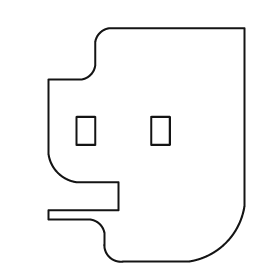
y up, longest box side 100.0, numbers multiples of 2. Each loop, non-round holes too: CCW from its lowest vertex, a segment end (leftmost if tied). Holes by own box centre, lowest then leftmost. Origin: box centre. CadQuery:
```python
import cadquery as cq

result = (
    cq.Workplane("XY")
    .moveTo(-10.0, -50.0)
    .lineTo(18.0, -50.0)
    .threePointArc((34.0, -42.0), (42.0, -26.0))
    .lineTo(42.0, 50.0)
    .lineTo(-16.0, 50.0)
    .threePointArc((-20.0, 48.0), (-22.0, 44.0))
    .lineTo(-22.0, 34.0)
    .threePointArc((-24.0, 30.0), (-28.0, 28.0))
    .lineTo(-42.0, 28.0)
    .lineTo(-42.0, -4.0)
    .threePointArc((-38.0, -12.0), (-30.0, -16.0))
    .lineTo(-12.0, -16.0)
    .lineTo(-12.0, -28.0)
    .lineTo(-42.0, -28.0)
    .lineTo(-42.0, -32.0)
    .lineTo(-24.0, -32.0)
    .threePointArc((-20.0, -34.0), (-18.0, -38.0))
    .lineTo(-18.0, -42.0)
    .threePointArc((-16.0, -48.0), (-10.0, -50.0))
    .close()
    .moveTo(-30.0, 0.0)
    .lineTo(-22.0, 0.0)
    .lineTo(-22.0, 12.0)
    .lineTo(-30.0, 12.0)
    .close()
    .moveTo(2.0, 0.0)
    .lineTo(10.0, 0.0)
    .lineTo(10.0, 12.0)
    .lineTo(2.0, 12.0)
    .close()
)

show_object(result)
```